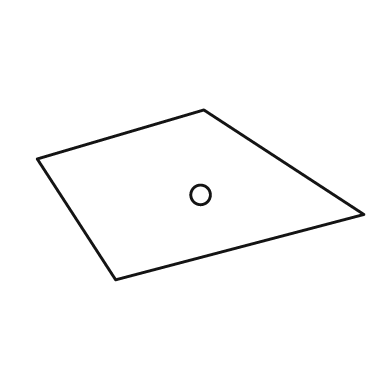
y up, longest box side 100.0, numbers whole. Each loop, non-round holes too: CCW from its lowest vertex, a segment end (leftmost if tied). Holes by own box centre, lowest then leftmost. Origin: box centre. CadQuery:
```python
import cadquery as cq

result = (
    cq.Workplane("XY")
    .moveTo(-26.0, -26.0)
    .lineTo(50.0, -6.0)
    .lineTo(1.0, 26.0)
    .lineTo(-50.0, 11.0)
    .close()
    .moveTo(0.0, 0.0)
    .circle(3.0)
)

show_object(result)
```